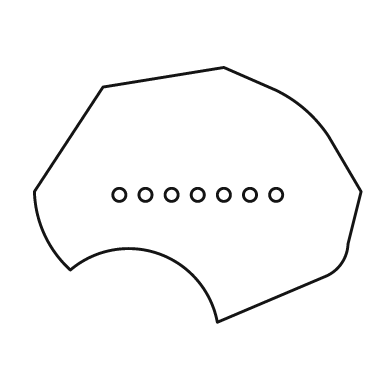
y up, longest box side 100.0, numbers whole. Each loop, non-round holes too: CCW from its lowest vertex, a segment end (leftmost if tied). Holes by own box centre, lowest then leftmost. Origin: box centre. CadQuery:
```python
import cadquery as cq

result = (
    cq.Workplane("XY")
    .moveTo(6.0, -39.0)
    .lineTo(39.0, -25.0)
    .threePointArc((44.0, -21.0), (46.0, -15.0))
    .lineTo(50.0, 1.0)
    .lineTo(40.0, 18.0)
    .threePointArc((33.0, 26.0), (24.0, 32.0))
    .lineTo(8.0, 39.0)
    .lineTo(-29.0, 33.0)
    .lineTo(-50.0, 1.0)
    .threePointArc((-47.0, -12.0), (-39.0, -23.0))
    .threePointArc((-12.0, -18.0), (6.0, -39.0))
    .close()
    .moveTo(-24.0, 0.0)
    .circle(2.0)
    .moveTo(-16.0, 0.0)
    .circle(2.0)
    .moveTo(-8.0, 0.0)
    .circle(2.0)
    .moveTo(0.0, 0.0)
    .circle(2.0)
    .moveTo(8.0, 0.0)
    .circle(2.0)
    .moveTo(16.0, 0.0)
    .circle(2.0)
    .moveTo(24.0, 0.0)
    .circle(2.0)
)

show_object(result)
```